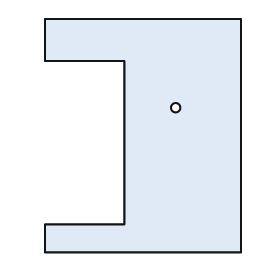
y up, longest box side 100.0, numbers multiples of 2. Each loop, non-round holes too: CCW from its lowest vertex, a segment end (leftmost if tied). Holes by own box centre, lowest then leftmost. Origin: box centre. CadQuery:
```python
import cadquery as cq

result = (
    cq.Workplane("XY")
    .moveTo(-42.0, -50.0)
    .lineTo(42.0, -50.0)
    .lineTo(42.0, 50.0)
    .lineTo(-42.0, 50.0)
    .lineTo(-42.0, 32.0)
    .lineTo(-8.0, 32.0)
    .lineTo(-8.0, -38.0)
    .lineTo(-42.0, -38.0)
    .close()
    .moveTo(14.0, 12.0)
    .circle(2.0)
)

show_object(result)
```